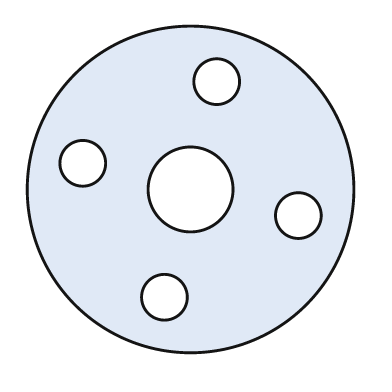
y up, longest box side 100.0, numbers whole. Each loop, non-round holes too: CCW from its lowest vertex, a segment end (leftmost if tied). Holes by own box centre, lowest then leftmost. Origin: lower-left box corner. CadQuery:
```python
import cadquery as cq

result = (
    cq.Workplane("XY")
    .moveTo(50.0, 50.0)
    .circle(50.0)
    .moveTo(42.0, 17.0)
    .circle(7.0)
    .moveTo(83.0, 42.0)
    .circle(7.0)
    .moveTo(50.0, 50.0)
    .circle(13.0)
    .moveTo(17.0, 58.0)
    .circle(7.0)
    .moveTo(58.0, 83.0)
    .circle(7.0)
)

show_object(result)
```